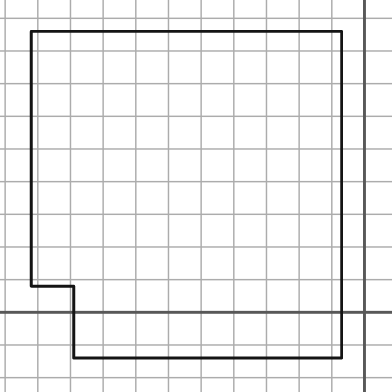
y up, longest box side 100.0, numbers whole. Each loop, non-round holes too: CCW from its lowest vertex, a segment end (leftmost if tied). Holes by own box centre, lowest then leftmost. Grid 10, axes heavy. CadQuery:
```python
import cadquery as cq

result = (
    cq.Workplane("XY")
    .moveTo(-89.0, -14.0)
    .lineTo(-7.0, -14.0)
    .lineTo(-7.0, 86.0)
    .lineTo(-102.0, 86.0)
    .lineTo(-102.0, 8.0)
    .lineTo(-89.0, 8.0)
    .close()
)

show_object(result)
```